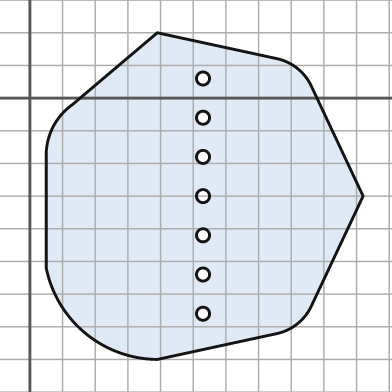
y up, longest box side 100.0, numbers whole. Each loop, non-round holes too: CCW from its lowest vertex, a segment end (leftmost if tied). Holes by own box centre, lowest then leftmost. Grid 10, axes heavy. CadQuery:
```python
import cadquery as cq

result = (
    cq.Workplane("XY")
    .moveTo(39.0, -80.0)
    .lineTo(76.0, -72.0)
    .threePointArc((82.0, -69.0), (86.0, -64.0))
    .lineTo(102.0, -30.0)
    .lineTo(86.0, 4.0)
    .threePointArc((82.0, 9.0), (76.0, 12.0))
    .lineTo(39.0, 20.0)
    .lineTo(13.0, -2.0)
    .threePointArc((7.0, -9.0), (5.0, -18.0))
    .lineTo(5.0, -52.0)
    .threePointArc((17.0, -72.0), (39.0, -80.0))
    .close()
    .moveTo(53.0, -66.0)
    .circle(2.0)
    .moveTo(53.0, -54.0)
    .circle(2.0)
    .moveTo(53.0, -42.0)
    .circle(2.0)
    .moveTo(53.0, -30.0)
    .circle(2.0)
    .moveTo(53.0, -18.0)
    .circle(2.0)
    .moveTo(53.0, -6.0)
    .circle(2.0)
    .moveTo(53.0, 6.0)
    .circle(2.0)
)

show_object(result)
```